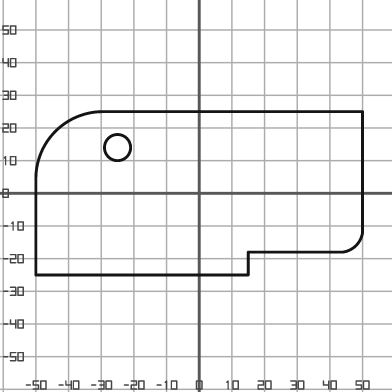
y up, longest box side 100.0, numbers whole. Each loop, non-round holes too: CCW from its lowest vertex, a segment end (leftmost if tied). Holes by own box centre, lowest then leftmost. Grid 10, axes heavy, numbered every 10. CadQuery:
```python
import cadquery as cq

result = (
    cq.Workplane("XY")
    .moveTo(-50.0, -25.0)
    .lineTo(15.0, -25.0)
    .lineTo(15.0, -18.0)
    .lineTo(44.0, -18.0)
    .threePointArc((48.0, -16.0), (50.0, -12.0))
    .lineTo(50.0, 25.0)
    .lineTo(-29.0, 25.0)
    .threePointArc((-44.0, 19.0), (-50.0, 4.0))
    .close()
    .moveTo(-25.0, 14.0)
    .circle(4.0)
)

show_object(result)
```